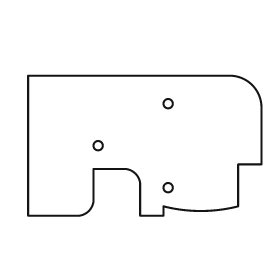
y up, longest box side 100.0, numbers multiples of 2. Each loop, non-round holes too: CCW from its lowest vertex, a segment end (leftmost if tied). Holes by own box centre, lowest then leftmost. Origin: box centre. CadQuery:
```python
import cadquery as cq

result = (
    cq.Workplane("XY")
    .moveTo(-50.0, -30.0)
    .lineTo(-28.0, -30.0)
    .threePointArc((-24.0, -28.0), (-22.0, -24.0))
    .lineTo(-22.0, -10.0)
    .lineTo(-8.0, -10.0)
    .threePointArc((-4.0, -12.0), (-2.0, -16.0))
    .lineTo(-2.0, -30.0)
    .lineTo(8.0, -30.0)
    .lineTo(8.0, -26.0)
    .threePointArc((24.0, -28.0), (40.0, -26.0))
    .lineTo(40.0, -8.0)
    .lineTo(50.0, -8.0)
    .lineTo(50.0, 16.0)
    .threePointArc((46.0, 26.0), (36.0, 30.0))
    .lineTo(-50.0, 30.0)
    .close()
    .moveTo(10.0, -18.0)
    .circle(2.0)
    .moveTo(-20.0, 0.0)
    .circle(2.0)
    .moveTo(10.0, 18.0)
    .circle(2.0)
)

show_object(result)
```